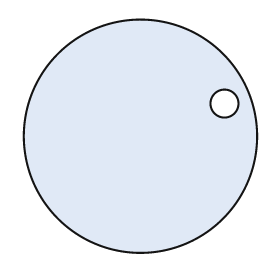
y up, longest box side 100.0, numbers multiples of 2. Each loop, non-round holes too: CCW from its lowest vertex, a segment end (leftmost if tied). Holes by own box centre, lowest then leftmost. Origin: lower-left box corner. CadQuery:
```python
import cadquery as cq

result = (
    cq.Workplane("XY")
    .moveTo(50.0, 50.0)
    .circle(50.0)
    .moveTo(86.0, 64.0)
    .circle(6.0)
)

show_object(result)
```